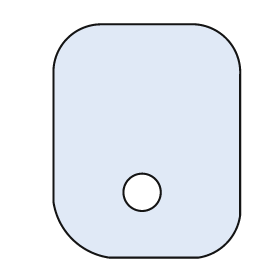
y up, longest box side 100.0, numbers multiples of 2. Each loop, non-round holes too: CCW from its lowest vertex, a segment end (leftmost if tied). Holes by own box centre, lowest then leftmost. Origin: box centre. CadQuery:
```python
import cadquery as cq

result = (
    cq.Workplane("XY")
    .moveTo(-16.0, -50.0)
    .lineTo(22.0, -50.0)
    .threePointArc((34.0, -44.0), (40.0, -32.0))
    .lineTo(40.0, 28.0)
    .threePointArc((34.0, 44.0), (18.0, 50.0))
    .lineTo(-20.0, 50.0)
    .threePointArc((-34.0, 44.0), (-40.0, 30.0))
    .lineTo(-40.0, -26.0)
    .threePointArc((-32.0, -42.0), (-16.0, -50.0))
    .close()
    .moveTo(-2.0, -22.0)
    .circle(8.0)
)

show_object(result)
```